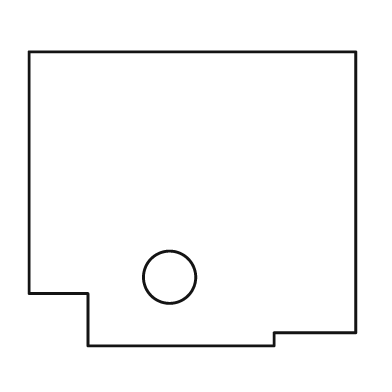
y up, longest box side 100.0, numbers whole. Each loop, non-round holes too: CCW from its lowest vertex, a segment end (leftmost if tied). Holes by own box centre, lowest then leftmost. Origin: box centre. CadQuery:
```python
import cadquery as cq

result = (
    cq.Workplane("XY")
    .moveTo(-32.0, -45.0)
    .lineTo(25.0, -45.0)
    .lineTo(25.0, -41.0)
    .lineTo(50.0, -41.0)
    .lineTo(50.0, 45.0)
    .lineTo(-50.0, 45.0)
    .lineTo(-50.0, -29.0)
    .lineTo(-32.0, -29.0)
    .close()
    .moveTo(-7.0, -24.0)
    .circle(8.0)
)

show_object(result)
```